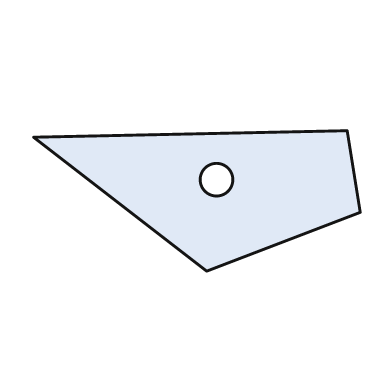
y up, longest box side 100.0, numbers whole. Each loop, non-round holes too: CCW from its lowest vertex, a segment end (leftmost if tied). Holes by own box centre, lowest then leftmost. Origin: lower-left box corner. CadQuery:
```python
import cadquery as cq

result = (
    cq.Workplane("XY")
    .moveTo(53.0, 0.0)
    .lineTo(100.0, 18.0)
    .lineTo(96.0, 43.0)
    .lineTo(0.0, 41.0)
    .close()
    .moveTo(56.0, 28.0)
    .circle(5.0)
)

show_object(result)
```